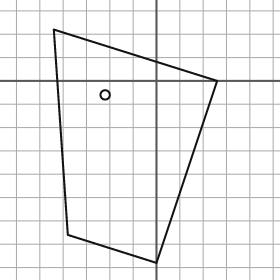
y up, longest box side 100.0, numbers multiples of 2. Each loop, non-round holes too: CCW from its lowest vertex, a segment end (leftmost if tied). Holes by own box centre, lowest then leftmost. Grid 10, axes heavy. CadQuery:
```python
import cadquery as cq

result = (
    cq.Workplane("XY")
    .moveTo(0.0, -78.0)
    .lineTo(26.0, 0.0)
    .lineTo(-44.0, 22.0)
    .lineTo(-38.0, -66.0)
    .close()
    .moveTo(-22.0, -6.0)
    .circle(2.0)
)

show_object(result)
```